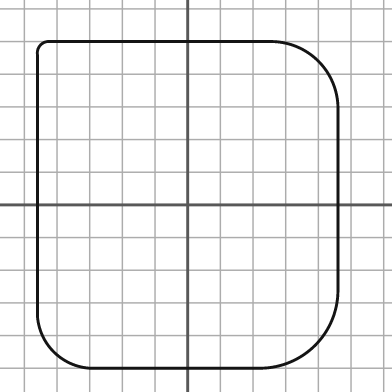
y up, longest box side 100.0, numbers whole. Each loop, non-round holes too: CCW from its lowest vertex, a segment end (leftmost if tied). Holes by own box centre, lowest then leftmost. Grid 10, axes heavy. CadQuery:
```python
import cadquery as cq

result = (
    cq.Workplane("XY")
    .moveTo(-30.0, -50.0)
    .lineTo(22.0, -50.0)
    .threePointArc((39.0, -43.0), (46.0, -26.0))
    .lineTo(46.0, 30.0)
    .threePointArc((40.0, 44.0), (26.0, 50.0))
    .lineTo(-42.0, 50.0)
    .threePointArc((-45.0, 49.0), (-46.0, 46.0))
    .lineTo(-46.0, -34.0)
    .threePointArc((-41.0, -45.0), (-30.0, -50.0))
    .close()
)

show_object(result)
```